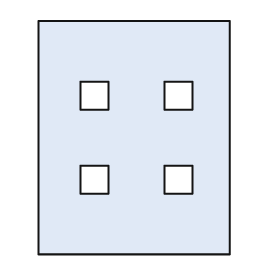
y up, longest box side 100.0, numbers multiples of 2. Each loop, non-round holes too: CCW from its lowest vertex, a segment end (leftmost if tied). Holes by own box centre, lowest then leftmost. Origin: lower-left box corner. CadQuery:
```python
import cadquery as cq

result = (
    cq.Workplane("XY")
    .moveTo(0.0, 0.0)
    .lineTo(82.0, 0.0)
    .lineTo(82.0, 100.0)
    .lineTo(0.0, 100.0)
    .close()
    .moveTo(18.0, 26.0)
    .lineTo(30.0, 26.0)
    .lineTo(30.0, 38.0)
    .lineTo(18.0, 38.0)
    .close()
    .moveTo(54.0, 26.0)
    .lineTo(66.0, 26.0)
    .lineTo(66.0, 38.0)
    .lineTo(54.0, 38.0)
    .close()
    .moveTo(18.0, 62.0)
    .lineTo(30.0, 62.0)
    .lineTo(30.0, 74.0)
    .lineTo(18.0, 74.0)
    .close()
    .moveTo(54.0, 62.0)
    .lineTo(66.0, 62.0)
    .lineTo(66.0, 74.0)
    .lineTo(54.0, 74.0)
    .close()
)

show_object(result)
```